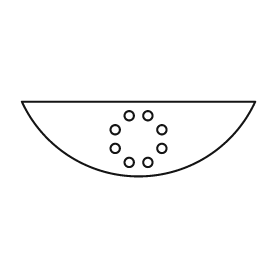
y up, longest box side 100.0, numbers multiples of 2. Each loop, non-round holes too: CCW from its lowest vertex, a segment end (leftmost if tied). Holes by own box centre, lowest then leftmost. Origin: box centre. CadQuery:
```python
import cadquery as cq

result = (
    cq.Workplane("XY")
    .moveTo(-50.0, 16.0)
    .threePointArc((0.0, -16.0), (50.0, 16.0))
    .close()
    .moveTo(-4.0, -10.0)
    .circle(2.0)
    .moveTo(4.0, -10.0)
    .circle(2.0)
    .moveTo(-10.0, -4.0)
    .circle(2.0)
    .moveTo(10.0, -4.0)
    .circle(2.0)
    .moveTo(-10.0, 4.0)
    .circle(2.0)
    .moveTo(10.0, 4.0)
    .circle(2.0)
    .moveTo(-4.0, 10.0)
    .circle(2.0)
    .moveTo(4.0, 10.0)
    .circle(2.0)
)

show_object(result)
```